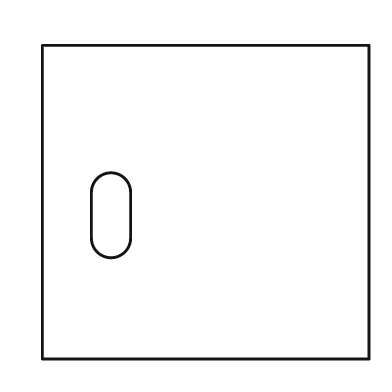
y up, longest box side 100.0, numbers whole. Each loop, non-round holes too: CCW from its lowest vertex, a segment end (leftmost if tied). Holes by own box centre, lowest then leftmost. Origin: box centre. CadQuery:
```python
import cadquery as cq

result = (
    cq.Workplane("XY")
    .moveTo(-50.0, -48.0)
    .lineTo(50.0, -48.0)
    .lineTo(50.0, 48.0)
    .lineTo(-50.0, 48.0)
    .close()
    .moveTo(-35.0, -11.0)
    .threePointArc((-29.0, -17.0), (-23.0, -11.0))
    .lineTo(-23.0, 3.0)
    .threePointArc((-29.0, 9.0), (-35.0, 3.0))
    .close()
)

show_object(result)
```